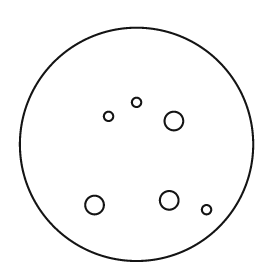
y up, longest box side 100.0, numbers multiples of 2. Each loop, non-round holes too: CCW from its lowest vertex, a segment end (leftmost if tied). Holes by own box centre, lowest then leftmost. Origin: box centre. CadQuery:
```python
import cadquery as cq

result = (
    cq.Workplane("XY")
    .moveTo(0.0, 0.0)
    .circle(50.0)
    .moveTo(30.0, -28.0)
    .circle(2.0)
    .moveTo(-18.0, -26.0)
    .circle(4.0)
    .moveTo(14.0, -24.0)
    .circle(4.0)
    .moveTo(16.0, 10.0)
    .circle(4.0)
    .moveTo(-12.0, 12.0)
    .circle(2.0)
    .moveTo(0.0, 18.0)
    .circle(2.0)
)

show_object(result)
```